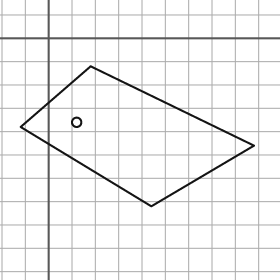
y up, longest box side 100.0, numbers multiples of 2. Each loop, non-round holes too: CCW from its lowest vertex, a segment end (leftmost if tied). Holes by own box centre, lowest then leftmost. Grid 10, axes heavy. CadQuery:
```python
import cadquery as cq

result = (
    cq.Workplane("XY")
    .moveTo(44.0, -72.0)
    .lineTo(88.0, -46.0)
    .lineTo(18.0, -12.0)
    .lineTo(-12.0, -38.0)
    .close()
    .moveTo(12.0, -36.0)
    .circle(2.0)
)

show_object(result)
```